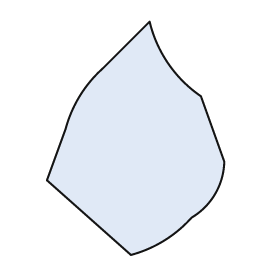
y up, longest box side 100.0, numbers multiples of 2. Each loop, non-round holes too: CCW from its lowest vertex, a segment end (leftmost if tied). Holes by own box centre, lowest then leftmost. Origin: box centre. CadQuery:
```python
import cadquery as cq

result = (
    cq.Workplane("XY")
    .moveTo(-2.0, -50.0)
    .threePointArc((12.0, -44.0), (24.0, -34.0))
    .threePointArc((34.0, -24.0), (38.0, -10.0))
    .lineTo(28.0, 18.0)
    .threePointArc((14.0, 32.0), (6.0, 50.0))
    .lineTo(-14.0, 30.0)
    .threePointArc((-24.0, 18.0), (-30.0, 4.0))
    .lineTo(-38.0, -18.0)
    .close()
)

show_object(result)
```